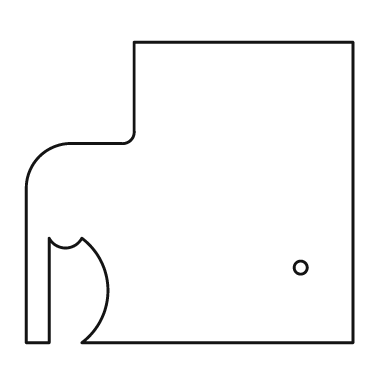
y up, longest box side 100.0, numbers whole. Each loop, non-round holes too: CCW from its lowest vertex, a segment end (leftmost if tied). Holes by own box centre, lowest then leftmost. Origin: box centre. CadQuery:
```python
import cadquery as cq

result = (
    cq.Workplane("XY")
    .moveTo(-50.0, -46.0)
    .lineTo(-43.0, -46.0)
    .lineTo(-43.0, -14.0)
    .threePointArc((-38.0, -17.0), (-33.0, -14.0))
    .threePointArc((-25.0, -30.0), (-33.0, -46.0))
    .lineTo(50.0, -46.0)
    .lineTo(50.0, 46.0)
    .lineTo(-17.0, 46.0)
    .lineTo(-17.0, 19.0)
    .threePointArc((-18.0, 16.0), (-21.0, 15.0))
    .lineTo(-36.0, 15.0)
    .threePointArc((-46.0, 11.0), (-50.0, 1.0))
    .close()
    .moveTo(34.0, -23.0)
    .circle(2.0)
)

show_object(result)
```